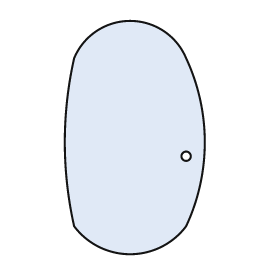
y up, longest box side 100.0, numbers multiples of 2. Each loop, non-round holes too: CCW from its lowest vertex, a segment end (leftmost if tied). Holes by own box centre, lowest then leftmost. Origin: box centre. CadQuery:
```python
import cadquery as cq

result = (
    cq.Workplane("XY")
    .moveTo(-26.0, -38.0)
    .threePointArc((-2.0, -50.0), (22.0, -38.0))
    .threePointArc((30.0, -2.0), (22.0, 34.0))
    .threePointArc((-2.0, 50.0), (-26.0, 34.0))
    .threePointArc((-30.0, -2.0), (-26.0, -38.0))
    .close()
    .moveTo(22.0, -8.0)
    .circle(2.0)
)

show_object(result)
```